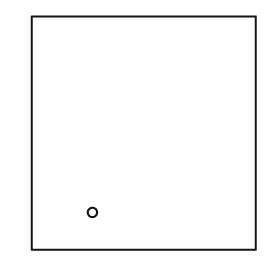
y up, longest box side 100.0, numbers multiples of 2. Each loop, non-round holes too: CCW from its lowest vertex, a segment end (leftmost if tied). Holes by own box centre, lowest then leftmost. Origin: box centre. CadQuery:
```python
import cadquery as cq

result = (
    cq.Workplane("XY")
    .moveTo(-48.0, -50.0)
    .lineTo(48.0, -50.0)
    .lineTo(48.0, 50.0)
    .lineTo(-48.0, 50.0)
    .close()
    .moveTo(-22.0, -34.0)
    .circle(2.0)
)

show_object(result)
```